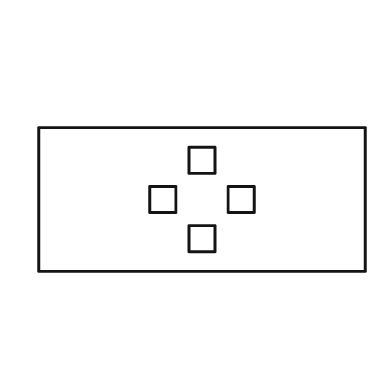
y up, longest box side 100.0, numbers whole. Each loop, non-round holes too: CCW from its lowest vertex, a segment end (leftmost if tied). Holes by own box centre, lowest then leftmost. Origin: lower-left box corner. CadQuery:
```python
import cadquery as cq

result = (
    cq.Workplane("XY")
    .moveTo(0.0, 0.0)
    .lineTo(100.0, 0.0)
    .lineTo(100.0, 44.0)
    .lineTo(0.0, 44.0)
    .close()
    .moveTo(46.0, 6.0)
    .lineTo(54.0, 6.0)
    .lineTo(54.0, 14.0)
    .lineTo(46.0, 14.0)
    .close()
    .moveTo(34.0, 18.0)
    .lineTo(42.0, 18.0)
    .lineTo(42.0, 26.0)
    .lineTo(34.0, 26.0)
    .close()
    .moveTo(58.0, 18.0)
    .lineTo(66.0, 18.0)
    .lineTo(66.0, 26.0)
    .lineTo(58.0, 26.0)
    .close()
    .moveTo(46.0, 30.0)
    .lineTo(54.0, 30.0)
    .lineTo(54.0, 38.0)
    .lineTo(46.0, 38.0)
    .close()
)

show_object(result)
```